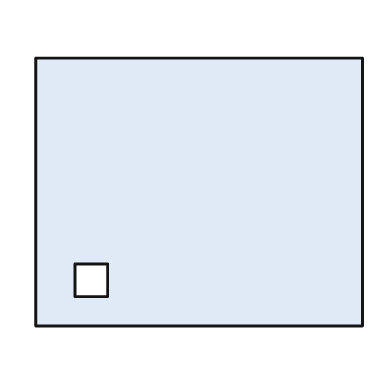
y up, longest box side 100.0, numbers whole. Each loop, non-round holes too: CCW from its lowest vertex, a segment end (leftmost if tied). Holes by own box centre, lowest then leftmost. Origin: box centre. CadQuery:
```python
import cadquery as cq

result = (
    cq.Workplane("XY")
    .moveTo(-50.0, -41.0)
    .lineTo(50.0, -41.0)
    .lineTo(50.0, 41.0)
    .lineTo(-50.0, 41.0)
    .close()
    .moveTo(-38.0, -32.0)
    .lineTo(-28.0, -32.0)
    .lineTo(-28.0, -22.0)
    .lineTo(-38.0, -22.0)
    .close()
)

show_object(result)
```